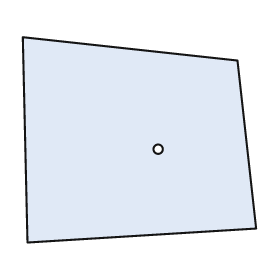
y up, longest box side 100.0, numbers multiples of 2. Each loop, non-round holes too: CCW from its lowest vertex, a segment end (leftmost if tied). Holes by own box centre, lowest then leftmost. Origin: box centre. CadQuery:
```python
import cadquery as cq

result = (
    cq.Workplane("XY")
    .moveTo(-48.0, -44.0)
    .lineTo(50.0, -38.0)
    .lineTo(42.0, 34.0)
    .lineTo(-50.0, 44.0)
    .close()
    .moveTo(8.0, -4.0)
    .circle(2.0)
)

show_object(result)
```